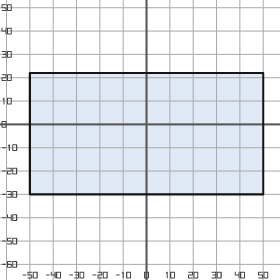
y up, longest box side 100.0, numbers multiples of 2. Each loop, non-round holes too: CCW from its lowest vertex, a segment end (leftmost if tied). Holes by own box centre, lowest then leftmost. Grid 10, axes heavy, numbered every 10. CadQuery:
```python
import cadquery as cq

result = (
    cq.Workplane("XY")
    .moveTo(-50.0, -30.0)
    .lineTo(50.0, -30.0)
    .lineTo(50.0, 22.0)
    .lineTo(-50.0, 22.0)
    .close()
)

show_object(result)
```